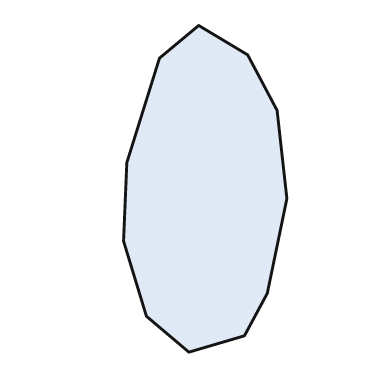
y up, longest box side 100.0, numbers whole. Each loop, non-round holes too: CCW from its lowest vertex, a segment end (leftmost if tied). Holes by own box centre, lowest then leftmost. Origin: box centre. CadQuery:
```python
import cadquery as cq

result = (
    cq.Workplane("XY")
    .moveTo(-5.0, -50.0)
    .lineTo(12.0, -45.0)
    .lineTo(19.0, -32.0)
    .lineTo(25.0, -3.0)
    .lineTo(22.0, 24.0)
    .lineTo(13.0, 41.0)
    .lineTo(-2.0, 50.0)
    .lineTo(-14.0, 40.0)
    .lineTo(-24.0, 8.0)
    .lineTo(-25.0, -16.0)
    .lineTo(-18.0, -39.0)
    .close()
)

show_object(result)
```